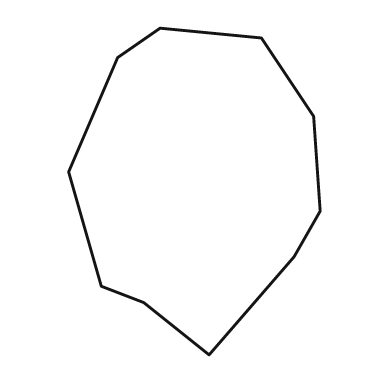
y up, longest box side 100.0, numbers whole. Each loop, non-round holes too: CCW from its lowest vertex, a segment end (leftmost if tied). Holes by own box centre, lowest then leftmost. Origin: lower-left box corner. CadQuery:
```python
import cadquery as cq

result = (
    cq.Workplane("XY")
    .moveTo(43.0, 0.0)
    .lineTo(69.0, 30.0)
    .lineTo(77.0, 44.0)
    .lineTo(75.0, 73.0)
    .lineTo(59.0, 97.0)
    .lineTo(28.0, 100.0)
    .lineTo(15.0, 91.0)
    .lineTo(0.0, 56.0)
    .lineTo(10.0, 21.0)
    .lineTo(23.0, 16.0)
    .close()
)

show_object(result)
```